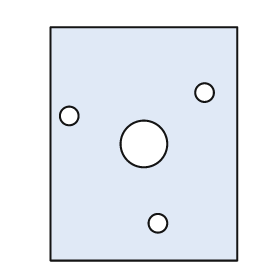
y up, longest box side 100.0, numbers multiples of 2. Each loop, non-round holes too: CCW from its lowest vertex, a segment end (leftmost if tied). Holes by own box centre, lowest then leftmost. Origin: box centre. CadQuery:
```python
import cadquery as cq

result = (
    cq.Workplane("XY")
    .moveTo(-40.0, -50.0)
    .lineTo(40.0, -50.0)
    .lineTo(40.0, 50.0)
    .lineTo(-40.0, 50.0)
    .close()
    .moveTo(6.0, -34.0)
    .circle(4.0)
    .moveTo(0.0, 0.0)
    .circle(10.0)
    .moveTo(-32.0, 12.0)
    .circle(4.0)
    .moveTo(26.0, 22.0)
    .circle(4.0)
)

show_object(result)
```